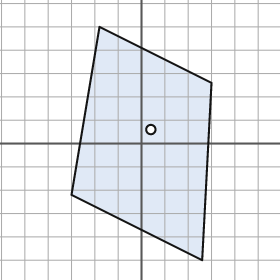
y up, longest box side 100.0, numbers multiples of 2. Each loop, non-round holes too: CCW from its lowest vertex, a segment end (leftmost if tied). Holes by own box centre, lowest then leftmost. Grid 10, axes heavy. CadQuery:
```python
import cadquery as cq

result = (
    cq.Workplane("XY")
    .moveTo(26.0, -50.0)
    .lineTo(30.0, 26.0)
    .lineTo(-18.0, 50.0)
    .lineTo(-30.0, -22.0)
    .close()
    .moveTo(4.0, 6.0)
    .circle(2.0)
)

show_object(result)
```